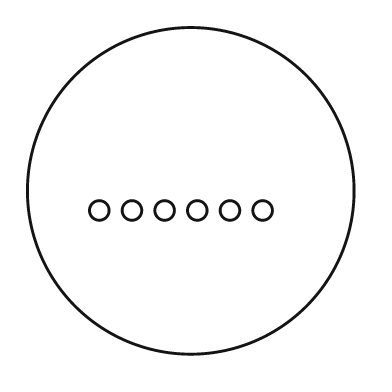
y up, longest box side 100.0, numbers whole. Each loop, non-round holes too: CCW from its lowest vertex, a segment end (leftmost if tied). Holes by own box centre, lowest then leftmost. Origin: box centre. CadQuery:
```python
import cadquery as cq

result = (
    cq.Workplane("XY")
    .moveTo(0.0, 0.0)
    .circle(50.0)
    .moveTo(-28.0, -6.0)
    .circle(3.0)
    .moveTo(-18.0, -6.0)
    .circle(3.0)
    .moveTo(-8.0, -6.0)
    .circle(3.0)
    .moveTo(2.0, -6.0)
    .circle(3.0)
    .moveTo(12.0, -6.0)
    .circle(3.0)
    .moveTo(22.0, -6.0)
    .circle(3.0)
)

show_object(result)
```